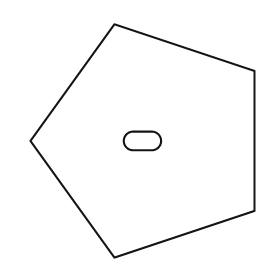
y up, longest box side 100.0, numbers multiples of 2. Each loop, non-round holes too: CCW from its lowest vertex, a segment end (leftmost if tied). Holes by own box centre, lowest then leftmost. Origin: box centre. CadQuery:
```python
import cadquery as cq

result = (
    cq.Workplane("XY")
    .moveTo(-12.0, -50.0)
    .lineTo(48.0, -30.0)
    .lineTo(48.0, 30.0)
    .lineTo(-12.0, 50.0)
    .lineTo(-48.0, 0.0)
    .close()
    .moveTo(-4.0, -4.0)
    .lineTo(4.0, -4.0)
    .threePointArc((8.0, 0.0), (4.0, 4.0))
    .lineTo(-4.0, 4.0)
    .threePointArc((-8.0, 0.0), (-4.0, -4.0))
    .close()
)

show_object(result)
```